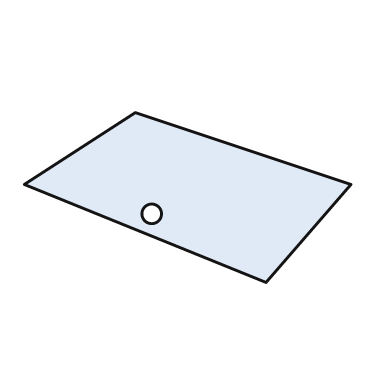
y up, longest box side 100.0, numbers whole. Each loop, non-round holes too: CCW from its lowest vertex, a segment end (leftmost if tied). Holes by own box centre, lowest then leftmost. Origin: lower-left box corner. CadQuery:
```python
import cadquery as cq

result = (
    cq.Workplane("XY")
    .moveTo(74.0, 0.0)
    .lineTo(100.0, 30.0)
    .lineTo(34.0, 52.0)
    .lineTo(0.0, 30.0)
    .close()
    .moveTo(39.0, 21.0)
    .circle(3.0)
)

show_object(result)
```